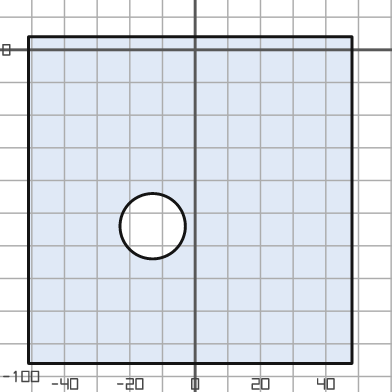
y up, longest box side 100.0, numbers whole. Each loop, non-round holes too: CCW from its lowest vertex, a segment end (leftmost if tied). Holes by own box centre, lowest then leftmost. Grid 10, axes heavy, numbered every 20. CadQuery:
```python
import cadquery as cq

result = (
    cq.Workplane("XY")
    .moveTo(-51.0, -96.0)
    .lineTo(48.0, -96.0)
    .lineTo(48.0, 4.0)
    .lineTo(-51.0, 4.0)
    .close()
    .moveTo(-13.0, -54.0)
    .circle(10.0)
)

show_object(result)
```